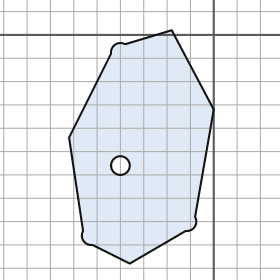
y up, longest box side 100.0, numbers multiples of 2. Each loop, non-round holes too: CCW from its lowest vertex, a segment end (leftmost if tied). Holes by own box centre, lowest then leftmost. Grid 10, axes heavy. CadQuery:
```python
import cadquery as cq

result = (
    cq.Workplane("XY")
    .moveTo(-36.0, -98.0)
    .lineTo(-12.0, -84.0)
    .threePointArc((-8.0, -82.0), (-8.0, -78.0))
    .lineTo(0.0, -32.0)
    .lineTo(-18.0, 2.0)
    .lineTo(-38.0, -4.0)
    .threePointArc((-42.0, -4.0), (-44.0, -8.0))
    .lineTo(-62.0, -44.0)
    .lineTo(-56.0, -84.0)
    .threePointArc((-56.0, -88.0), (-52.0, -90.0))
    .close()
    .moveTo(-40.0, -56.0)
    .circle(4.0)
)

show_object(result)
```